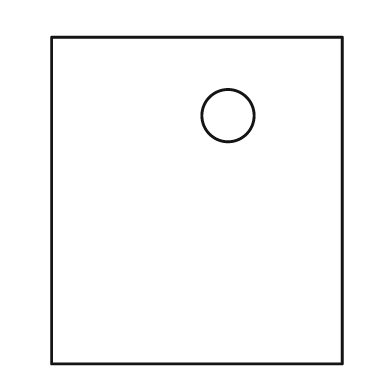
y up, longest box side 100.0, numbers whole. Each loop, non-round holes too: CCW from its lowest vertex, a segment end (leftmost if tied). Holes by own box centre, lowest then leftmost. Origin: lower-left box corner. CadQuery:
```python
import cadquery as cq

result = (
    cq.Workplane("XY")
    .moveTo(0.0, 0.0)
    .lineTo(89.0, 0.0)
    .lineTo(89.0, 100.0)
    .lineTo(0.0, 100.0)
    .close()
    .moveTo(54.0, 76.0)
    .circle(8.0)
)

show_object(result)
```